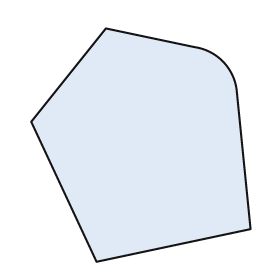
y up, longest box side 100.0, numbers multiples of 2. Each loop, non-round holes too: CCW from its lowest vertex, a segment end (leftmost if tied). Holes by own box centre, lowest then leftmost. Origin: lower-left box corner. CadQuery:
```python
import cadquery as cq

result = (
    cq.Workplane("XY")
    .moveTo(28.0, 0.0)
    .lineTo(94.0, 14.0)
    .lineTo(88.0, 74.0)
    .threePointArc((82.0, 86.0), (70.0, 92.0))
    .lineTo(32.0, 100.0)
    .lineTo(0.0, 60.0)
    .close()
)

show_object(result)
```